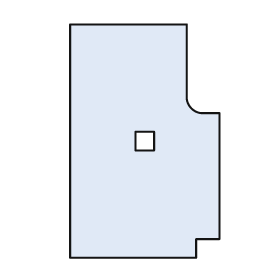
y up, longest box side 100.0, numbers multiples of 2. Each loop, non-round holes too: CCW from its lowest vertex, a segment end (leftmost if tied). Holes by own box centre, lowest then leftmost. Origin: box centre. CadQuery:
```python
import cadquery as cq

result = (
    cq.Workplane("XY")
    .moveTo(-32.0, -50.0)
    .lineTo(22.0, -50.0)
    .lineTo(22.0, -42.0)
    .lineTo(32.0, -42.0)
    .lineTo(32.0, 12.0)
    .lineTo(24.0, 12.0)
    .threePointArc((20.0, 14.0), (18.0, 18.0))
    .lineTo(18.0, 50.0)
    .lineTo(-32.0, 50.0)
    .close()
    .moveTo(-4.0, -4.0)
    .lineTo(4.0, -4.0)
    .lineTo(4.0, 4.0)
    .lineTo(-4.0, 4.0)
    .close()
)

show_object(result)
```